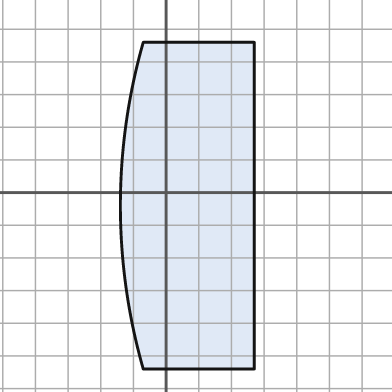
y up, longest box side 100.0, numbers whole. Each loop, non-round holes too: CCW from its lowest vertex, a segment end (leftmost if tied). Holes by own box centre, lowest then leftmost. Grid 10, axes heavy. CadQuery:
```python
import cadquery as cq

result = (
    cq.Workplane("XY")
    .moveTo(-7.0, -54.0)
    .lineTo(27.0, -54.0)
    .lineTo(27.0, 46.0)
    .lineTo(-7.0, 46.0)
    .threePointArc((-14.0, -4.0), (-7.0, -54.0))
    .close()
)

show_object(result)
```